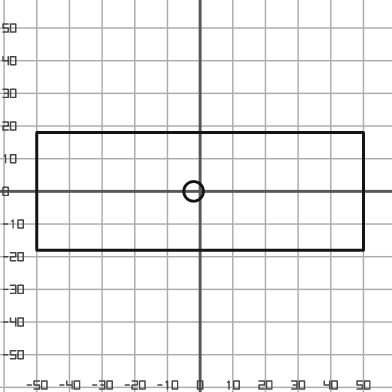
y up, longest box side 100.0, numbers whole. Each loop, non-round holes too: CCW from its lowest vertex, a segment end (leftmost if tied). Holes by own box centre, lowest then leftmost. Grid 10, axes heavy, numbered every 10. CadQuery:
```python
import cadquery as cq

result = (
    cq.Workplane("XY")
    .moveTo(-50.0, -18.0)
    .lineTo(50.0, -18.0)
    .lineTo(50.0, 18.0)
    .lineTo(-50.0, 18.0)
    .close()
    .moveTo(-2.0, 0.0)
    .circle(3.0)
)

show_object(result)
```